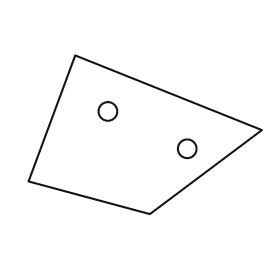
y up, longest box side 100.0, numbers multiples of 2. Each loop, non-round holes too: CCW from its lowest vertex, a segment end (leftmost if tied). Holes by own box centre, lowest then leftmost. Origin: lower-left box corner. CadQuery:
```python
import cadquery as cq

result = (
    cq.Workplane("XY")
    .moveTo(52.0, 0.0)
    .lineTo(100.0, 36.0)
    .lineTo(20.0, 68.0)
    .lineTo(0.0, 14.0)
    .close()
    .moveTo(68.0, 28.0)
    .circle(4.0)
    .moveTo(34.0, 44.0)
    .circle(4.0)
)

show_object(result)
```